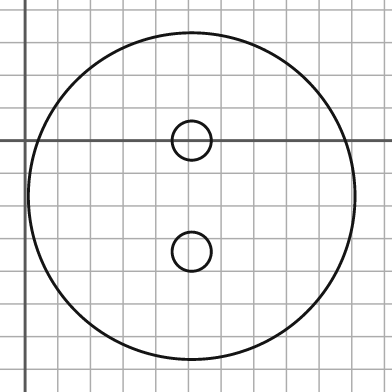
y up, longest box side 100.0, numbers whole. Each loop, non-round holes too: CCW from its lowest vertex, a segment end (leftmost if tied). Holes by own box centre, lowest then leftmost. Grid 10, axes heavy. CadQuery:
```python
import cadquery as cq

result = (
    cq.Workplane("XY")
    .moveTo(51.0, -17.0)
    .circle(50.0)
    .moveTo(51.0, -34.0)
    .circle(6.0)
    .moveTo(51.0, 0.0)
    .circle(6.0)
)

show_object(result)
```